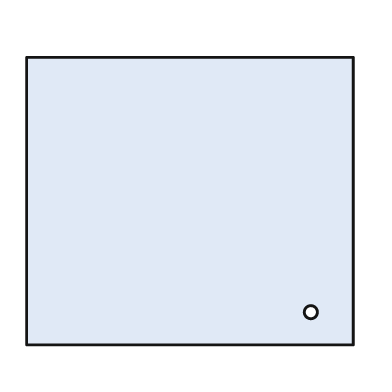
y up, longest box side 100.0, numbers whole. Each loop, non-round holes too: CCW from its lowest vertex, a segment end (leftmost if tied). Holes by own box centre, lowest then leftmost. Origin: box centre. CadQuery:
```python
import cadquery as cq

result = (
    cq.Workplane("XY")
    .moveTo(-50.0, -44.0)
    .lineTo(50.0, -44.0)
    .lineTo(50.0, 44.0)
    .lineTo(-50.0, 44.0)
    .close()
    .moveTo(37.0, -34.0)
    .circle(2.0)
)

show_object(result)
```